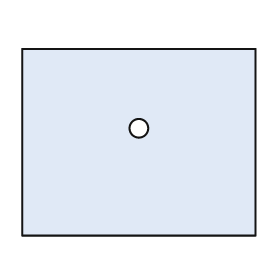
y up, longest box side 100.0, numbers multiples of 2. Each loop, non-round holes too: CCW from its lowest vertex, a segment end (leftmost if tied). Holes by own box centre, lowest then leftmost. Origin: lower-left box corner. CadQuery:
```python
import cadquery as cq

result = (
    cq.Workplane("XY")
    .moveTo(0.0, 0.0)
    .lineTo(100.0, 0.0)
    .lineTo(100.0, 80.0)
    .lineTo(0.0, 80.0)
    .close()
    .moveTo(50.0, 46.0)
    .circle(4.0)
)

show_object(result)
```